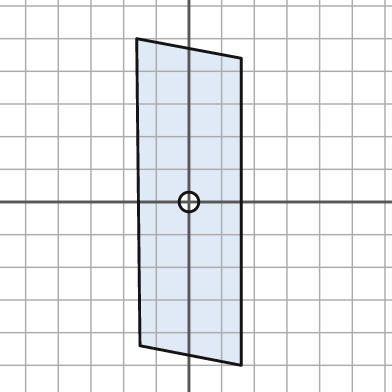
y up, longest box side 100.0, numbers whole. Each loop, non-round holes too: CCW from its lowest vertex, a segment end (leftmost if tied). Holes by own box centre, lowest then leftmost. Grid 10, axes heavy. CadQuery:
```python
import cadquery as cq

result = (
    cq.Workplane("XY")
    .moveTo(16.0, -50.0)
    .lineTo(16.0, 44.0)
    .lineTo(-16.0, 50.0)
    .lineTo(-15.0, -44.0)
    .close()
    .moveTo(0.0, 0.0)
    .circle(3.0)
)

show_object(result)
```